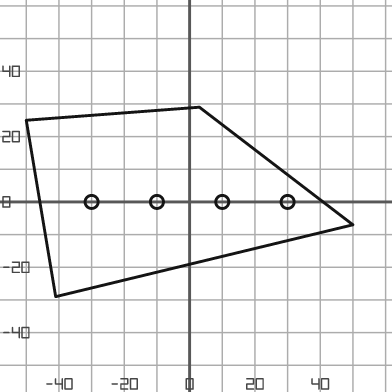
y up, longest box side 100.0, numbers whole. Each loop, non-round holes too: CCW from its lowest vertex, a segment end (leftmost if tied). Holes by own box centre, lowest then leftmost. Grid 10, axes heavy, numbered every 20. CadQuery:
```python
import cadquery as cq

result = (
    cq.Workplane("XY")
    .moveTo(-41.0, -29.0)
    .lineTo(50.0, -7.0)
    .lineTo(3.0, 29.0)
    .lineTo(-50.0, 25.0)
    .close()
    .moveTo(-30.0, 0.0)
    .circle(2.0)
    .moveTo(-10.0, 0.0)
    .circle(2.0)
    .moveTo(10.0, 0.0)
    .circle(2.0)
    .moveTo(30.0, 0.0)
    .circle(2.0)
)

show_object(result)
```